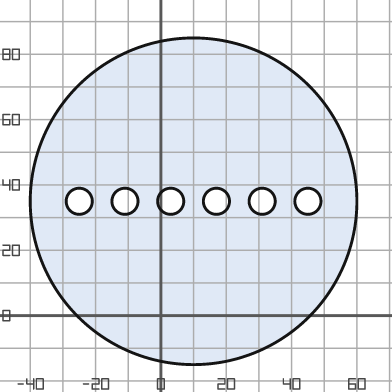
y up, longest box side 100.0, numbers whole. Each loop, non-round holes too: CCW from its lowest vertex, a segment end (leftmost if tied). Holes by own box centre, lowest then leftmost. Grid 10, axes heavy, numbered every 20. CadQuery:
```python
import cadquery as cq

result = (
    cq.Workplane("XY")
    .moveTo(10.0, 35.0)
    .circle(50.0)
    .moveTo(-25.0, 35.0)
    .circle(4.0)
    .moveTo(-11.0, 35.0)
    .circle(4.0)
    .moveTo(3.0, 35.0)
    .circle(4.0)
    .moveTo(17.0, 35.0)
    .circle(4.0)
    .moveTo(31.0, 35.0)
    .circle(4.0)
    .moveTo(45.0, 35.0)
    .circle(4.0)
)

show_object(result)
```